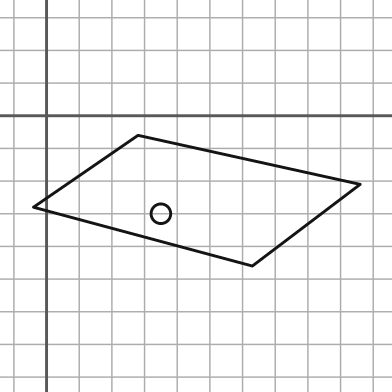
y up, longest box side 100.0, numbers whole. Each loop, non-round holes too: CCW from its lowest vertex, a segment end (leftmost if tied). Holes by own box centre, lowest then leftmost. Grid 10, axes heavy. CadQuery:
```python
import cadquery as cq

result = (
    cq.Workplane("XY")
    .moveTo(63.0, -46.0)
    .lineTo(96.0, -21.0)
    .lineTo(28.0, -6.0)
    .lineTo(-4.0, -28.0)
    .close()
    .moveTo(35.0, -30.0)
    .circle(3.0)
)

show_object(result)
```